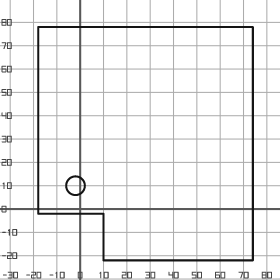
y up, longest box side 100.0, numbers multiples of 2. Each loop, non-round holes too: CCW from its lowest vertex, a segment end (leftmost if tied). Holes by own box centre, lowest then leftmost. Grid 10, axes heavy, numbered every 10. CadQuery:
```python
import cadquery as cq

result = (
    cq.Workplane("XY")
    .moveTo(10.0, -22.0)
    .lineTo(74.0, -22.0)
    .lineTo(74.0, 78.0)
    .lineTo(-18.0, 78.0)
    .lineTo(-18.0, -2.0)
    .lineTo(10.0, -2.0)
    .close()
    .moveTo(-2.0, 10.0)
    .circle(4.0)
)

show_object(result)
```